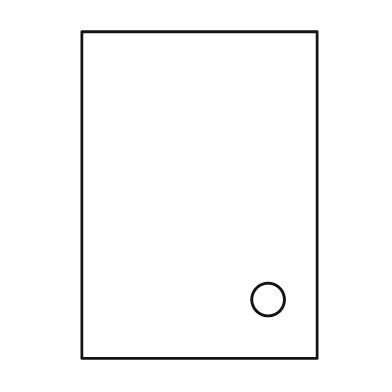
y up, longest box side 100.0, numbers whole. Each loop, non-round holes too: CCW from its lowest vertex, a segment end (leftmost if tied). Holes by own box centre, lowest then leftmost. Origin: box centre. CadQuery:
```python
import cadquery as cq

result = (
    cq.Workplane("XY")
    .moveTo(-36.0, -50.0)
    .lineTo(36.0, -50.0)
    .lineTo(36.0, 50.0)
    .lineTo(-36.0, 50.0)
    .close()
    .moveTo(21.0, -32.0)
    .circle(5.0)
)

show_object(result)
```